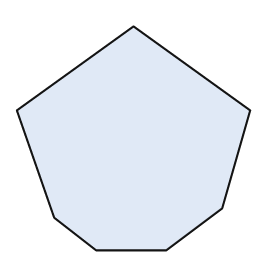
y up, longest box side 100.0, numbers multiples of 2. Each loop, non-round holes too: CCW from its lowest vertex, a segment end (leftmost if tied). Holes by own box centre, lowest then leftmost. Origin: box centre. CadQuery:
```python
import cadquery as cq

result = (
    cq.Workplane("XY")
    .moveTo(-16.0, -48.0)
    .lineTo(14.0, -48.0)
    .lineTo(38.0, -30.0)
    .lineTo(50.0, 12.0)
    .lineTo(0.0, 48.0)
    .lineTo(-50.0, 12.0)
    .lineTo(-34.0, -34.0)
    .close()
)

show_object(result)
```